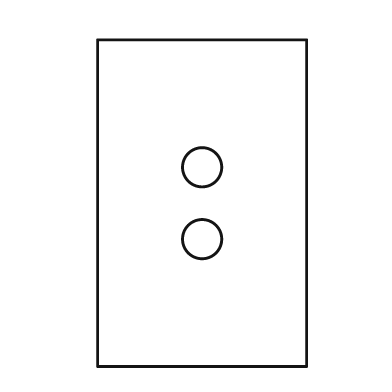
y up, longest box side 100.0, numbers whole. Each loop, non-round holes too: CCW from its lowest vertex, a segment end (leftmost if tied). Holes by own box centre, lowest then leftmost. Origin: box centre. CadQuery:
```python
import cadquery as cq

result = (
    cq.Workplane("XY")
    .moveTo(-32.0, -50.0)
    .lineTo(32.0, -50.0)
    .lineTo(32.0, 50.0)
    .lineTo(-32.0, 50.0)
    .close()
    .moveTo(0.0, -11.0)
    .circle(6.0)
    .moveTo(0.0, 11.0)
    .circle(6.0)
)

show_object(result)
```